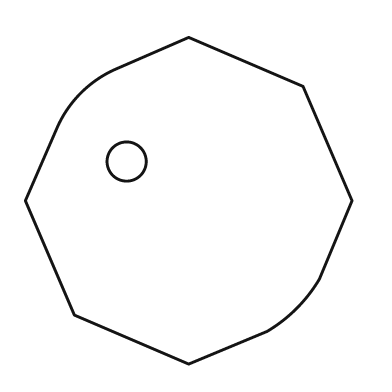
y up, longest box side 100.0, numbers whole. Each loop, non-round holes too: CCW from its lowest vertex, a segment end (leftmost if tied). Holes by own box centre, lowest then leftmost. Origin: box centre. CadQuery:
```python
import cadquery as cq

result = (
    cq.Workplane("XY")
    .moveTo(0.0, -50.0)
    .lineTo(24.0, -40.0)
    .threePointArc((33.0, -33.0), (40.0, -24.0))
    .lineTo(50.0, 0.0)
    .lineTo(35.0, 35.0)
    .lineTo(0.0, 50.0)
    .lineTo(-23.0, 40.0)
    .threePointArc((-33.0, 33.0), (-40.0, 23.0))
    .lineTo(-50.0, 0.0)
    .lineTo(-35.0, -35.0)
    .close()
    .moveTo(-19.0, 12.0)
    .circle(6.0)
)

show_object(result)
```